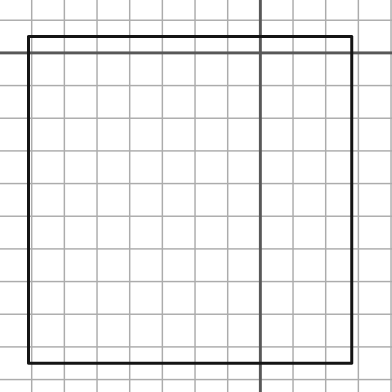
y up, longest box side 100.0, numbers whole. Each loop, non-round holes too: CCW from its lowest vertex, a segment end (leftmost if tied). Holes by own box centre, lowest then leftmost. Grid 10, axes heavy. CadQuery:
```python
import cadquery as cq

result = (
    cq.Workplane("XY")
    .moveTo(-71.0, -95.0)
    .lineTo(28.0, -95.0)
    .lineTo(28.0, 5.0)
    .lineTo(-71.0, 5.0)
    .close()
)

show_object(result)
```